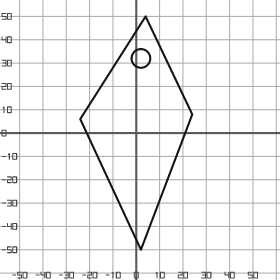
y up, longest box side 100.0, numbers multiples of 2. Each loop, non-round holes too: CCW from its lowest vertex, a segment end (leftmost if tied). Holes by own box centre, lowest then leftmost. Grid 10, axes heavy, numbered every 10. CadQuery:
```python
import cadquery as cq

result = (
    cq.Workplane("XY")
    .moveTo(2.0, -50.0)
    .lineTo(24.0, 8.0)
    .lineTo(4.0, 50.0)
    .lineTo(-24.0, 6.0)
    .close()
    .moveTo(2.0, 32.0)
    .circle(4.0)
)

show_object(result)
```